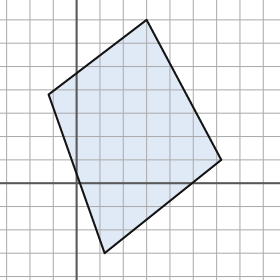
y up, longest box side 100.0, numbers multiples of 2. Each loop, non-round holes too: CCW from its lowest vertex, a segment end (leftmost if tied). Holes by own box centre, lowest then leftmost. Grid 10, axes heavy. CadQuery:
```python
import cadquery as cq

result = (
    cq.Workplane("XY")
    .moveTo(12.0, -30.0)
    .lineTo(62.0, 10.0)
    .lineTo(30.0, 70.0)
    .lineTo(-12.0, 38.0)
    .close()
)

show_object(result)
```